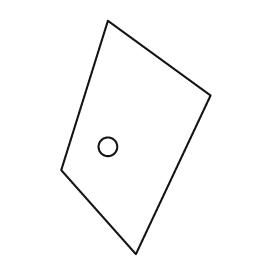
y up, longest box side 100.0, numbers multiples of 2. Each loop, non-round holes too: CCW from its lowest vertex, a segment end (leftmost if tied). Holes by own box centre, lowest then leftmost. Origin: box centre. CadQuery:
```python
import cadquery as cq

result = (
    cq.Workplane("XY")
    .moveTo(0.0, -50.0)
    .lineTo(32.0, 18.0)
    .lineTo(-12.0, 50.0)
    .lineTo(-32.0, -14.0)
    .close()
    .moveTo(-12.0, -4.0)
    .circle(4.0)
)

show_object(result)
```